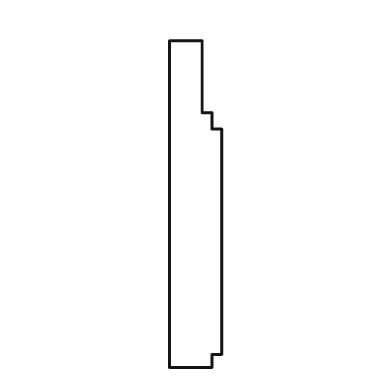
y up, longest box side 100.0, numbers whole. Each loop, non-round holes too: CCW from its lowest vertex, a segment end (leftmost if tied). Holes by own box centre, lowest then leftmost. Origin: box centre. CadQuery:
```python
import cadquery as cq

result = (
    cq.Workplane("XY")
    .moveTo(-8.0, -50.0)
    .lineTo(5.0, -50.0)
    .lineTo(5.0, -46.0)
    .lineTo(8.0, -46.0)
    .lineTo(8.0, 23.0)
    .lineTo(5.0, 23.0)
    .lineTo(5.0, 28.0)
    .lineTo(2.0, 28.0)
    .lineTo(2.0, 50.0)
    .lineTo(-8.0, 50.0)
    .close()
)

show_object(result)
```